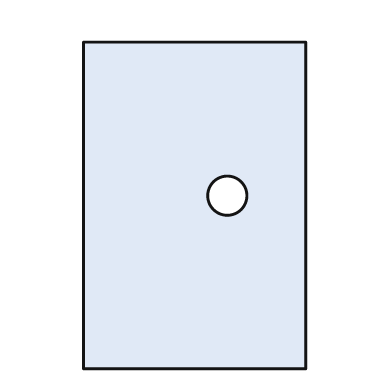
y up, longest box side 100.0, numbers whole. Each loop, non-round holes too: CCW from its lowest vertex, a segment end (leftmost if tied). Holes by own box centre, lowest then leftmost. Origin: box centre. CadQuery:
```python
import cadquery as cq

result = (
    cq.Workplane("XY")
    .moveTo(-34.0, -50.0)
    .lineTo(34.0, -50.0)
    .lineTo(34.0, 50.0)
    .lineTo(-34.0, 50.0)
    .close()
    .moveTo(10.0, 3.0)
    .circle(6.0)
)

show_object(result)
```